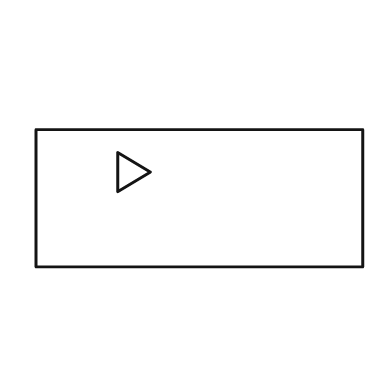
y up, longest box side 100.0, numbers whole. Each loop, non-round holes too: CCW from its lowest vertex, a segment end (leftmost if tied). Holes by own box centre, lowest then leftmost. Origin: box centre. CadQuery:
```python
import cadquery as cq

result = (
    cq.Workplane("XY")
    .moveTo(-50.0, -21.0)
    .lineTo(50.0, -21.0)
    .lineTo(50.0, 21.0)
    .lineTo(-50.0, 21.0)
    .close()
    .moveTo(-25.0, 2.0)
    .lineTo(-15.0, 8.0)
    .lineTo(-25.0, 14.0)
    .close()
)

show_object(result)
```